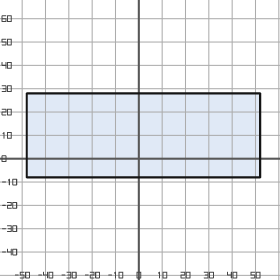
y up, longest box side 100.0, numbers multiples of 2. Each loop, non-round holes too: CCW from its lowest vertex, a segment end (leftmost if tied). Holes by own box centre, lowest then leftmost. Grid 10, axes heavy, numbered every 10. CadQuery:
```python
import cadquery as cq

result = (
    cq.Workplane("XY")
    .moveTo(-48.0, -8.0)
    .lineTo(52.0, -8.0)
    .lineTo(52.0, 28.0)
    .lineTo(-48.0, 28.0)
    .close()
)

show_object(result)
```